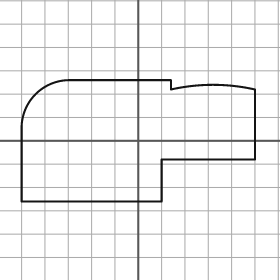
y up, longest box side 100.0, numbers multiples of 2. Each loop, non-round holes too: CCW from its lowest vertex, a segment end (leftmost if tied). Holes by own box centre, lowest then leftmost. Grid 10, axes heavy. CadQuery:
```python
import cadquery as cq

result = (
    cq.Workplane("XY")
    .moveTo(-50.0, -26.0)
    .lineTo(10.0, -26.0)
    .lineTo(10.0, -8.0)
    .lineTo(50.0, -8.0)
    .lineTo(50.0, 22.0)
    .threePointArc((32.0, 24.0), (14.0, 22.0))
    .lineTo(14.0, 26.0)
    .lineTo(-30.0, 26.0)
    .threePointArc((-44.0, 20.0), (-50.0, 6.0))
    .close()
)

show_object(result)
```